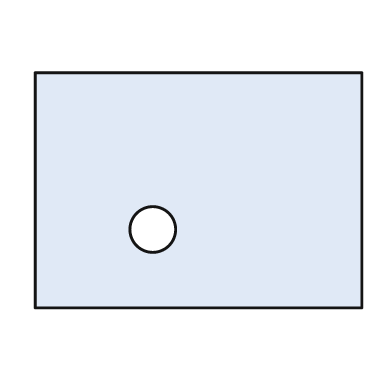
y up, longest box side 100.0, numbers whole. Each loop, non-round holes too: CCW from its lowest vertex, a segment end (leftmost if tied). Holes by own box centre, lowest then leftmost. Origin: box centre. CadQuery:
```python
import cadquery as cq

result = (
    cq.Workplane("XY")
    .moveTo(-50.0, -36.0)
    .lineTo(50.0, -36.0)
    .lineTo(50.0, 36.0)
    .lineTo(-50.0, 36.0)
    .close()
    .moveTo(-14.0, -12.0)
    .circle(7.0)
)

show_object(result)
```